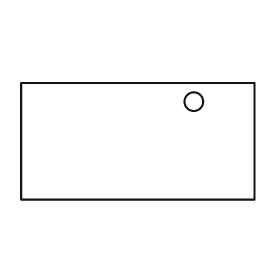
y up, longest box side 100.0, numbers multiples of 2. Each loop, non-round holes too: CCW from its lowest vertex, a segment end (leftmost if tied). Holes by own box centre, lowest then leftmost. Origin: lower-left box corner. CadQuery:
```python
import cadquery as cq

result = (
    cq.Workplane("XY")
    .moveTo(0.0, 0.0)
    .lineTo(100.0, 0.0)
    .lineTo(100.0, 50.0)
    .lineTo(0.0, 50.0)
    .close()
    .moveTo(74.0, 42.0)
    .circle(4.0)
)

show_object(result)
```